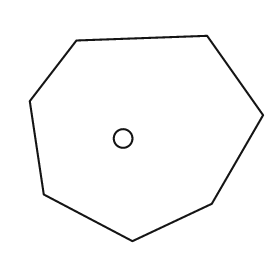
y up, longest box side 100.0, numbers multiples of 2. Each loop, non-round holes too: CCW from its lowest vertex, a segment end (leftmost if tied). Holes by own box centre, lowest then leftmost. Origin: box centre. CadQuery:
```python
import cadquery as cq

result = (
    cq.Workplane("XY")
    .moveTo(-6.0, -44.0)
    .lineTo(28.0, -28.0)
    .lineTo(50.0, 10.0)
    .lineTo(26.0, 44.0)
    .lineTo(-30.0, 42.0)
    .lineTo(-50.0, 16.0)
    .lineTo(-44.0, -24.0)
    .close()
    .moveTo(-10.0, 0.0)
    .circle(4.0)
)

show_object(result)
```